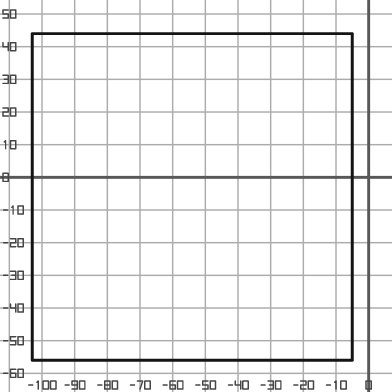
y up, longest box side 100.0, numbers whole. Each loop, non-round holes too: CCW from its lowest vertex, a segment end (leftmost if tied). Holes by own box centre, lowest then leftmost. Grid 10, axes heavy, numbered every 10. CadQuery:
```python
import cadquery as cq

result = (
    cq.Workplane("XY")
    .moveTo(-103.0, -56.0)
    .lineTo(-5.0, -56.0)
    .lineTo(-5.0, 44.0)
    .lineTo(-103.0, 44.0)
    .close()
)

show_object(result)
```